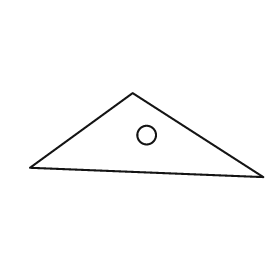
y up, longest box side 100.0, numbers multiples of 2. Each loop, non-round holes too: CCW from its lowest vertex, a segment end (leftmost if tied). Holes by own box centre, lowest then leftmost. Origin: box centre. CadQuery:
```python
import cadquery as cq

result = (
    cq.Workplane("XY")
    .moveTo(50.0, -18.0)
    .lineTo(-6.0, 18.0)
    .lineTo(-50.0, -14.0)
    .close()
    .moveTo(0.0, 0.0)
    .circle(4.0)
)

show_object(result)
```